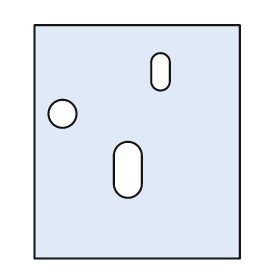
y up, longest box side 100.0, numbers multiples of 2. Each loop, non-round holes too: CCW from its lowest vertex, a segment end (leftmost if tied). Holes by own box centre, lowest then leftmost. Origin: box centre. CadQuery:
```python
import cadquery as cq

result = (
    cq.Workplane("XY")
    .moveTo(-44.0, -50.0)
    .lineTo(44.0, -50.0)
    .lineTo(44.0, 50.0)
    .lineTo(-44.0, 50.0)
    .close()
    .moveTo(-10.0, -18.0)
    .threePointArc((-4.0, -24.0), (2.0, -18.0))
    .lineTo(2.0, -6.0)
    .threePointArc((-4.0, 0.0), (-10.0, -6.0))
    .close()
    .moveTo(-32.0, 12.0)
    .circle(6.0)
    .moveTo(6.0, 26.0)
    .threePointArc((10.0, 22.0), (14.0, 26.0))
    .lineTo(14.0, 34.0)
    .threePointArc((10.0, 38.0), (6.0, 34.0))
    .close()
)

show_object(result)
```